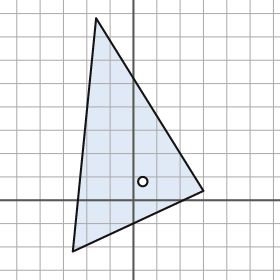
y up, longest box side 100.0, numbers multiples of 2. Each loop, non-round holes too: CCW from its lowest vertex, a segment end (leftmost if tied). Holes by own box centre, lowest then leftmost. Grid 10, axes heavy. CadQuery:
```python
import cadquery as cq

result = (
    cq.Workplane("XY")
    .moveTo(-26.0, -22.0)
    .lineTo(30.0, 4.0)
    .lineTo(-16.0, 78.0)
    .close()
    .moveTo(4.0, 8.0)
    .circle(2.0)
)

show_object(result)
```